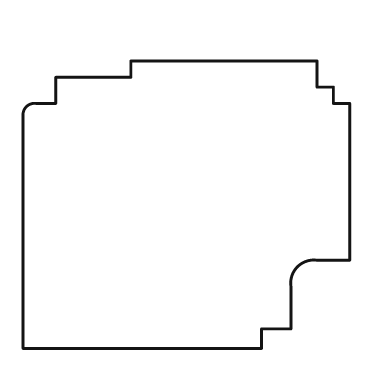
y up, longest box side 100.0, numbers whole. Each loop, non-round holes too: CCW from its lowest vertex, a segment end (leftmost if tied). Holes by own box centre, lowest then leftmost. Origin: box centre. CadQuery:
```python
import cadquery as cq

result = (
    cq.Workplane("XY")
    .moveTo(-50.0, -44.0)
    .lineTo(23.0, -44.0)
    .lineTo(23.0, -38.0)
    .lineTo(32.0, -38.0)
    .lineTo(32.0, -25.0)
    .threePointArc((34.0, -19.0), (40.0, -17.0))
    .lineTo(50.0, -17.0)
    .lineTo(50.0, 31.0)
    .lineTo(45.0, 31.0)
    .lineTo(45.0, 36.0)
    .lineTo(40.0, 36.0)
    .lineTo(40.0, 44.0)
    .lineTo(-17.0, 44.0)
    .lineTo(-17.0, 39.0)
    .lineTo(-40.0, 39.0)
    .lineTo(-40.0, 31.0)
    .lineTo(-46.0, 31.0)
    .threePointArc((-49.0, 30.0), (-50.0, 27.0))
    .close()
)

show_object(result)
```